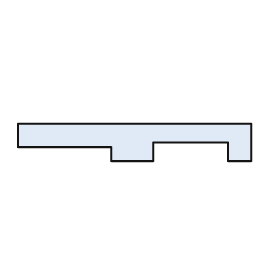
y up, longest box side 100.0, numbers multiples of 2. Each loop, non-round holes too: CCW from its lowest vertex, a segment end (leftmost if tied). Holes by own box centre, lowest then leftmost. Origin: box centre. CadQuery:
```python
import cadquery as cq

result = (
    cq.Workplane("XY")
    .moveTo(-10.0, -8.0)
    .lineTo(8.0, -8.0)
    .lineTo(8.0, 0.0)
    .lineTo(40.0, 0.0)
    .lineTo(40.0, -8.0)
    .lineTo(50.0, -8.0)
    .lineTo(50.0, 8.0)
    .lineTo(-50.0, 8.0)
    .lineTo(-50.0, -2.0)
    .lineTo(-10.0, -2.0)
    .close()
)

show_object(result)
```